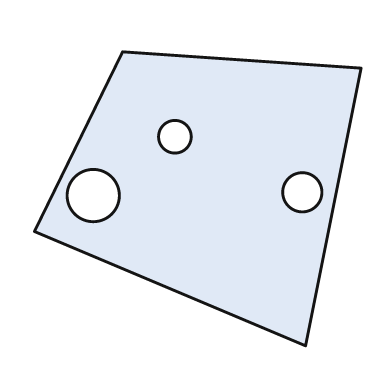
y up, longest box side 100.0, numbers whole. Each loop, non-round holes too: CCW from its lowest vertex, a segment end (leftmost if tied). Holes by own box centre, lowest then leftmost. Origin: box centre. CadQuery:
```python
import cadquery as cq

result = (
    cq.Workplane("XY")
    .moveTo(33.0, -45.0)
    .lineTo(50.0, 40.0)
    .lineTo(-23.0, 45.0)
    .lineTo(-50.0, -10.0)
    .close()
    .moveTo(-32.0, 1.0)
    .circle(8.0)
    .moveTo(32.0, 2.0)
    .circle(6.0)
    .moveTo(-7.0, 19.0)
    .circle(5.0)
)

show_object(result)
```